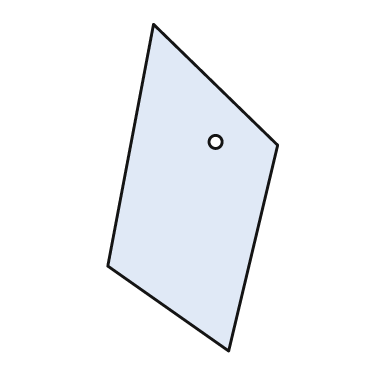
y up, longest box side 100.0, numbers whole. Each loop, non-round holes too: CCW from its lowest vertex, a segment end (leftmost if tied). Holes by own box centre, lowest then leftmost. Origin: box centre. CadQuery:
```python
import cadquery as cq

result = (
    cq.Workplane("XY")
    .moveTo(11.0, -50.0)
    .lineTo(26.0, 13.0)
    .lineTo(-12.0, 50.0)
    .lineTo(-26.0, -24.0)
    .close()
    .moveTo(7.0, 14.0)
    .circle(2.0)
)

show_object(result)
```